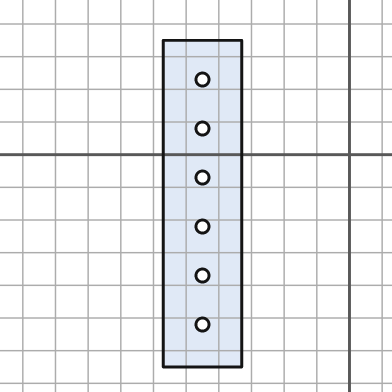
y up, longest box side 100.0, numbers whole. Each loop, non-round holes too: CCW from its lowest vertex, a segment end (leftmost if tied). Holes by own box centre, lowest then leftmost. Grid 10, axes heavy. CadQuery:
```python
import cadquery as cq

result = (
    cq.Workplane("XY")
    .moveTo(-57.0, -65.0)
    .lineTo(-33.0, -65.0)
    .lineTo(-33.0, 35.0)
    .lineTo(-57.0, 35.0)
    .close()
    .moveTo(-45.0, -52.0)
    .circle(2.0)
    .moveTo(-45.0, -37.0)
    .circle(2.0)
    .moveTo(-45.0, -22.0)
    .circle(2.0)
    .moveTo(-45.0, -7.0)
    .circle(2.0)
    .moveTo(-45.0, 8.0)
    .circle(2.0)
    .moveTo(-45.0, 23.0)
    .circle(2.0)
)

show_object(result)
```